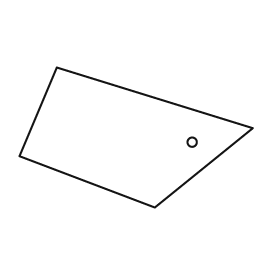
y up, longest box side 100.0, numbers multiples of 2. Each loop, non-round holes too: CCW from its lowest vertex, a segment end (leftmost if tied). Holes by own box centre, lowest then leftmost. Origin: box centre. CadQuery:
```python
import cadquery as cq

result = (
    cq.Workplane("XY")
    .moveTo(8.0, -30.0)
    .lineTo(50.0, 4.0)
    .lineTo(-34.0, 30.0)
    .lineTo(-50.0, -8.0)
    .close()
    .moveTo(24.0, -2.0)
    .circle(2.0)
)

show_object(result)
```